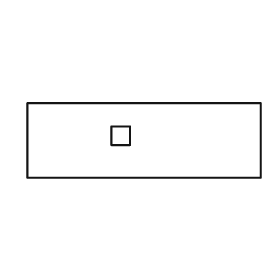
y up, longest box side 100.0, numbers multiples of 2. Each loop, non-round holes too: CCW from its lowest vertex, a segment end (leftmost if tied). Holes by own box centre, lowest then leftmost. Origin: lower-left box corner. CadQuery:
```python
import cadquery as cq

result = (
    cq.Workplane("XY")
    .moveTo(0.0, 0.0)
    .lineTo(100.0, 0.0)
    .lineTo(100.0, 32.0)
    .lineTo(0.0, 32.0)
    .close()
    .moveTo(36.0, 14.0)
    .lineTo(44.0, 14.0)
    .lineTo(44.0, 22.0)
    .lineTo(36.0, 22.0)
    .close()
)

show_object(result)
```